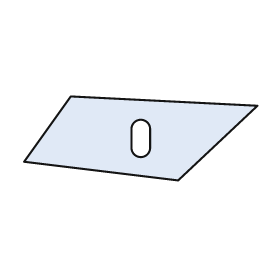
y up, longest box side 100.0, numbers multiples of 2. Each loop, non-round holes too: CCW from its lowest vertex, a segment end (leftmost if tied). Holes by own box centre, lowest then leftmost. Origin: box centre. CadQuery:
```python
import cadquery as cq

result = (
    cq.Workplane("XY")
    .moveTo(16.0, -18.0)
    .lineTo(50.0, 14.0)
    .lineTo(-30.0, 18.0)
    .lineTo(-50.0, -10.0)
    .close()
    .moveTo(-4.0, -4.0)
    .threePointArc((0.0, -8.0), (4.0, -4.0))
    .lineTo(4.0, 4.0)
    .threePointArc((0.0, 8.0), (-4.0, 4.0))
    .close()
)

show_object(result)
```